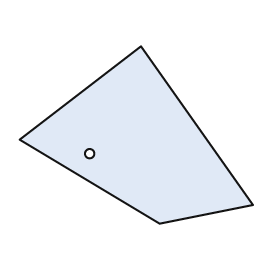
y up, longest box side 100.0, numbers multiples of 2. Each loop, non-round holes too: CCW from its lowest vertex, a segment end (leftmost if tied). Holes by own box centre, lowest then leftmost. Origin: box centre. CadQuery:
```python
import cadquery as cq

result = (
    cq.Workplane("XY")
    .moveTo(10.0, -38.0)
    .lineTo(50.0, -30.0)
    .lineTo(2.0, 38.0)
    .lineTo(-50.0, -2.0)
    .close()
    .moveTo(-20.0, -8.0)
    .circle(2.0)
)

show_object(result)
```